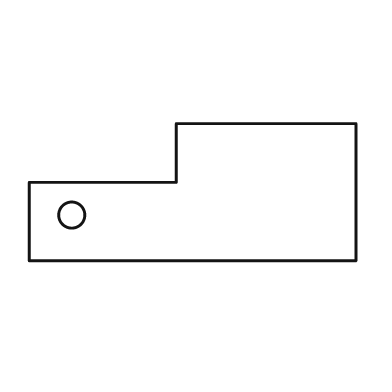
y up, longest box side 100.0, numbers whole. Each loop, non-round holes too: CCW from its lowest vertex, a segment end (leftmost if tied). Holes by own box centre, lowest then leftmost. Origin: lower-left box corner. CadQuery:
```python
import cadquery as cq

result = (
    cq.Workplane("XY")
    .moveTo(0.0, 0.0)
    .lineTo(100.0, 0.0)
    .lineTo(100.0, 42.0)
    .lineTo(45.0, 42.0)
    .lineTo(45.0, 24.0)
    .lineTo(0.0, 24.0)
    .close()
    .moveTo(13.0, 14.0)
    .circle(4.0)
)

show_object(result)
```